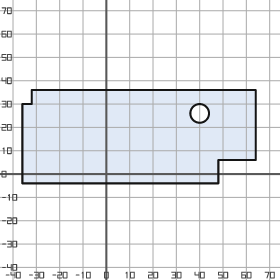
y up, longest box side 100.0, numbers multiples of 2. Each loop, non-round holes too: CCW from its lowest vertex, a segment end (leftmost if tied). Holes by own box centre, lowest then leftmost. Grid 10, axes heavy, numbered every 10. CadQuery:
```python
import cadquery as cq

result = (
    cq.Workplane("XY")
    .moveTo(-36.0, -4.0)
    .lineTo(48.0, -4.0)
    .lineTo(48.0, 6.0)
    .lineTo(64.0, 6.0)
    .lineTo(64.0, 36.0)
    .lineTo(-32.0, 36.0)
    .lineTo(-32.0, 30.0)
    .lineTo(-36.0, 30.0)
    .close()
    .moveTo(40.0, 26.0)
    .circle(4.0)
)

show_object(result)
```